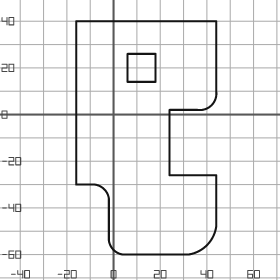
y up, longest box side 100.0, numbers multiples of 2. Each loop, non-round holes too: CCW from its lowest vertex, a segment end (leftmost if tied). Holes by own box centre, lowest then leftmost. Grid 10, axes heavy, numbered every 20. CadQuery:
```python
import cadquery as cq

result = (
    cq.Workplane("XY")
    .moveTo(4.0, -60.0)
    .lineTo(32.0, -60.0)
    .threePointArc((40.0, -56.0), (44.0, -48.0))
    .lineTo(44.0, -26.0)
    .lineTo(24.0, -26.0)
    .lineTo(24.0, 2.0)
    .lineTo(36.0, 2.0)
    .threePointArc((42.0, 4.0), (44.0, 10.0))
    .lineTo(44.0, 40.0)
    .lineTo(-16.0, 40.0)
    .lineTo(-16.0, -30.0)
    .lineTo(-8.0, -30.0)
    .threePointArc((-4.0, -32.0), (-2.0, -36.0))
    .lineTo(-2.0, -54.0)
    .threePointArc((0.0, -58.0), (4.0, -60.0))
    .close()
    .moveTo(6.0, 14.0)
    .lineTo(18.0, 14.0)
    .lineTo(18.0, 26.0)
    .lineTo(6.0, 26.0)
    .close()
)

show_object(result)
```